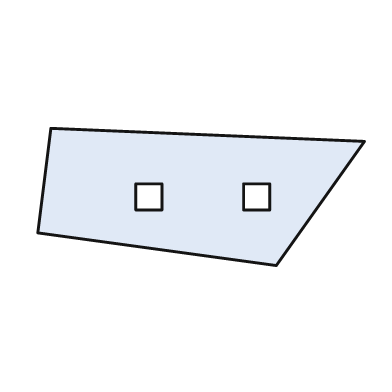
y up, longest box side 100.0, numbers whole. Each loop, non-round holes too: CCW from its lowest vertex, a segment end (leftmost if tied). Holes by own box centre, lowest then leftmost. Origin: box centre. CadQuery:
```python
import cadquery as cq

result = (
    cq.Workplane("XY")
    .moveTo(23.0, -21.0)
    .lineTo(50.0, 17.0)
    .lineTo(-46.0, 21.0)
    .lineTo(-50.0, -11.0)
    .close()
    .moveTo(-20.0, -4.0)
    .lineTo(-12.0, -4.0)
    .lineTo(-12.0, 4.0)
    .lineTo(-20.0, 4.0)
    .close()
    .moveTo(13.0, -4.0)
    .lineTo(21.0, -4.0)
    .lineTo(21.0, 4.0)
    .lineTo(13.0, 4.0)
    .close()
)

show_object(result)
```